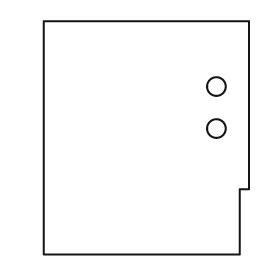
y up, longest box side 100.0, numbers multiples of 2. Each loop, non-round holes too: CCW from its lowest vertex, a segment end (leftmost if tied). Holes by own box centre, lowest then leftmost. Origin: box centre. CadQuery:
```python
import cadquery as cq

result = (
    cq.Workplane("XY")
    .moveTo(-44.0, -50.0)
    .lineTo(40.0, -50.0)
    .lineTo(40.0, -22.0)
    .lineTo(44.0, -22.0)
    .lineTo(44.0, 50.0)
    .lineTo(-44.0, 50.0)
    .close()
    .moveTo(30.0, 4.0)
    .circle(4.0)
    .moveTo(30.0, 22.0)
    .circle(4.0)
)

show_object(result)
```